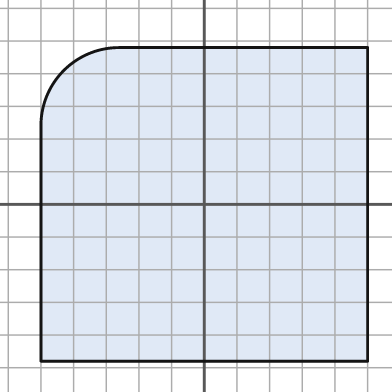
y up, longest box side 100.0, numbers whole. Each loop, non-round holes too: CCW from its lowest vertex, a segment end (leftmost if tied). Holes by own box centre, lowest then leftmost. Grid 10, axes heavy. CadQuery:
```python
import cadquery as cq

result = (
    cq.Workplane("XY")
    .moveTo(-50.0, -48.0)
    .lineTo(50.0, -48.0)
    .lineTo(50.0, 48.0)
    .lineTo(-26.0, 48.0)
    .threePointArc((-43.0, 41.0), (-50.0, 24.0))
    .close()
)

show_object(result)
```